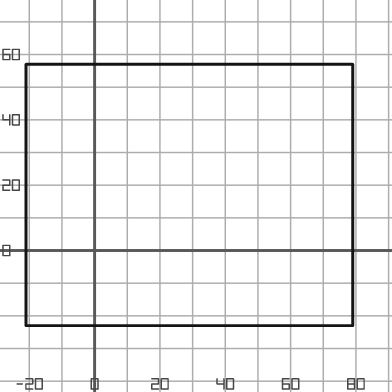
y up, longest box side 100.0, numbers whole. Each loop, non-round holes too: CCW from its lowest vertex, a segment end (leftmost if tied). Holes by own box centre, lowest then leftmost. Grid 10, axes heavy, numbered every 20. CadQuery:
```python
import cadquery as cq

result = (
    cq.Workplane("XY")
    .moveTo(-21.0, -23.0)
    .lineTo(79.0, -23.0)
    .lineTo(79.0, 57.0)
    .lineTo(-21.0, 57.0)
    .close()
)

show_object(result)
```